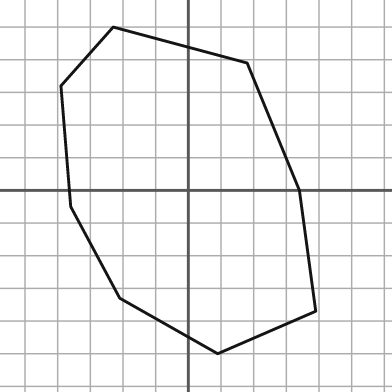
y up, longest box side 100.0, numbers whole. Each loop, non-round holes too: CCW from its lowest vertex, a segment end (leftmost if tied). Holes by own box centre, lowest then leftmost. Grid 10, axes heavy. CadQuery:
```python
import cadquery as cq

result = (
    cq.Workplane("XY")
    .moveTo(9.0, -50.0)
    .lineTo(39.0, -37.0)
    .lineTo(34.0, 0.0)
    .lineTo(18.0, 39.0)
    .lineTo(-23.0, 50.0)
    .lineTo(-39.0, 32.0)
    .lineTo(-36.0, -5.0)
    .lineTo(-21.0, -33.0)
    .close()
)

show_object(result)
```